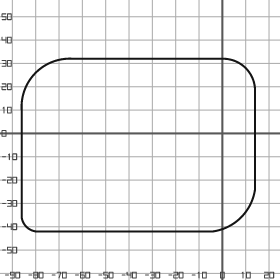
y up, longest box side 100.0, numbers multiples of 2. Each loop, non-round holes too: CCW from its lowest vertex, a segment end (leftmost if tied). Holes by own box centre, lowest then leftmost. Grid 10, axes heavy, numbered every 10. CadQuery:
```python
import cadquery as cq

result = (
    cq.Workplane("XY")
    .moveTo(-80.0, -42.0)
    .lineTo(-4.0, -42.0)
    .threePointArc((8.0, -36.0), (14.0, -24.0))
    .lineTo(14.0, 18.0)
    .threePointArc((10.0, 28.0), (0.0, 32.0))
    .lineTo(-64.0, 32.0)
    .threePointArc((-80.0, 26.0), (-86.0, 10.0))
    .lineTo(-86.0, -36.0)
    .threePointArc((-84.0, -40.0), (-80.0, -42.0))
    .close()
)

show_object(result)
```